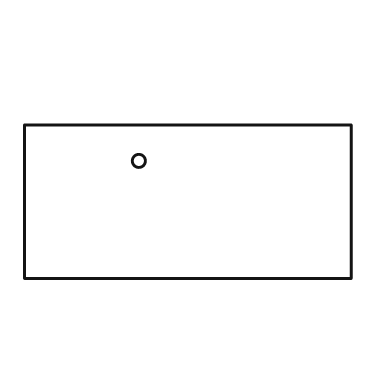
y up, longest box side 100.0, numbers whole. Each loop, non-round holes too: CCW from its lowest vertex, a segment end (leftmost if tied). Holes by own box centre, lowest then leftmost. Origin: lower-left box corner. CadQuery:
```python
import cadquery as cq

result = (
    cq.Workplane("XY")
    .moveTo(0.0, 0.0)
    .lineTo(100.0, 0.0)
    .lineTo(100.0, 47.0)
    .lineTo(0.0, 47.0)
    .close()
    .moveTo(35.0, 36.0)
    .circle(2.0)
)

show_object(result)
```